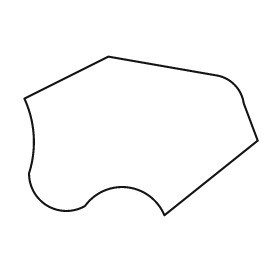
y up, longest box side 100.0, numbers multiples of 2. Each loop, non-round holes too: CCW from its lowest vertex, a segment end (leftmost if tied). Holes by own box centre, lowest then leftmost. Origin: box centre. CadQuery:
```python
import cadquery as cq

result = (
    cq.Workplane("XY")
    .moveTo(10.0, -34.0)
    .lineTo(50.0, -2.0)
    .lineTo(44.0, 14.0)
    .threePointArc((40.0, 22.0), (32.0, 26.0))
    .lineTo(-14.0, 34.0)
    .lineTo(-50.0, 16.0)
    .threePointArc((-46.0, 0.0), (-48.0, -16.0))
    .threePointArc((-40.0, -30.0), (-24.0, -30.0))
    .threePointArc((-6.0, -22.0), (10.0, -34.0))
    .close()
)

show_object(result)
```